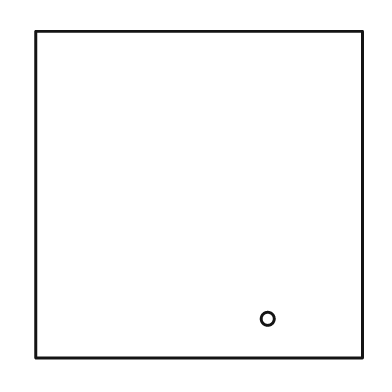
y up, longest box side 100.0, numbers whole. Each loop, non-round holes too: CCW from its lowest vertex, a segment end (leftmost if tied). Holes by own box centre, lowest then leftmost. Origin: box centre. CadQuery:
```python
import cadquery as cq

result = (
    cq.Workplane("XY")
    .moveTo(-50.0, -50.0)
    .lineTo(50.0, -50.0)
    .lineTo(50.0, 50.0)
    .lineTo(-50.0, 50.0)
    .close()
    .moveTo(21.0, -38.0)
    .circle(2.0)
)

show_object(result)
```